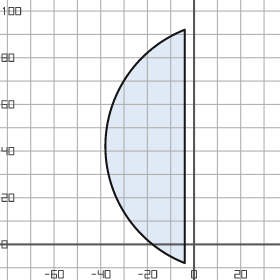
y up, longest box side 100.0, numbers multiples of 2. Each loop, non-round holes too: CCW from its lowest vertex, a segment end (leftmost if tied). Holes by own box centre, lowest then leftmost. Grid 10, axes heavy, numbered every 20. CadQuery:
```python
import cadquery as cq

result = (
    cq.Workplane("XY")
    .moveTo(-4.0, -8.0)
    .lineTo(-4.0, 92.0)
    .threePointArc((-38.0, 42.0), (-4.0, -8.0))
    .close()
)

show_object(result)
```